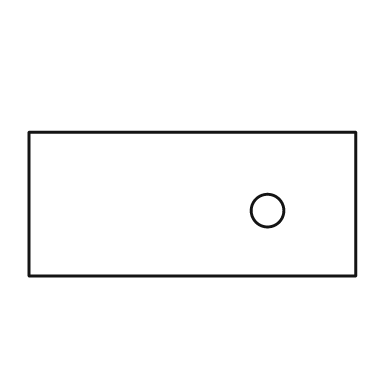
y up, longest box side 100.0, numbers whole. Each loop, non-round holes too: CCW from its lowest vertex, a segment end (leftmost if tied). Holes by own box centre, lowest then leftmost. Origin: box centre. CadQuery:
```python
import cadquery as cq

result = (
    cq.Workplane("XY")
    .moveTo(-50.0, -22.0)
    .lineTo(50.0, -22.0)
    .lineTo(50.0, 22.0)
    .lineTo(-50.0, 22.0)
    .close()
    .moveTo(23.0, -2.0)
    .circle(5.0)
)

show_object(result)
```